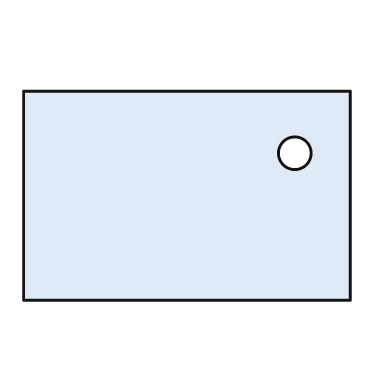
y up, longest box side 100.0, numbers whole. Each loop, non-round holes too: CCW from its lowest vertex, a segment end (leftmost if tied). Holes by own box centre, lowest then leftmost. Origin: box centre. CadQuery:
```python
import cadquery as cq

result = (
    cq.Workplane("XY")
    .moveTo(-50.0, -32.0)
    .lineTo(50.0, -32.0)
    .lineTo(50.0, 32.0)
    .lineTo(-50.0, 32.0)
    .close()
    .moveTo(33.0, 13.0)
    .circle(5.0)
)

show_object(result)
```